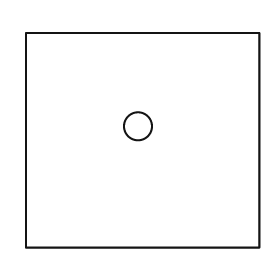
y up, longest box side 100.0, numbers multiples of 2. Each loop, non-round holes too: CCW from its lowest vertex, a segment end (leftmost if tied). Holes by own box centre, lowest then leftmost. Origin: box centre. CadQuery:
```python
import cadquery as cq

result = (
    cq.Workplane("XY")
    .moveTo(-50.0, -46.0)
    .lineTo(50.0, -46.0)
    .lineTo(50.0, 46.0)
    .lineTo(-50.0, 46.0)
    .close()
    .moveTo(-2.0, 6.0)
    .circle(6.0)
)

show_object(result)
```